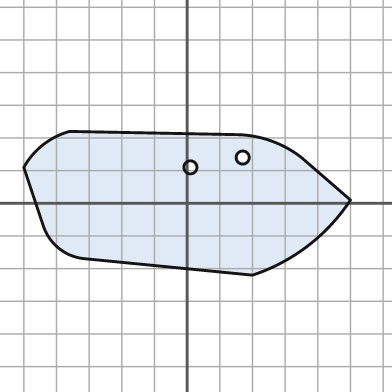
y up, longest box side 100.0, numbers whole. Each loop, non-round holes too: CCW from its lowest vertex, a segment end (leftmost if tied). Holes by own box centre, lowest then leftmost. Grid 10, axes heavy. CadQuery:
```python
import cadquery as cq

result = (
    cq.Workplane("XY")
    .moveTo(20.0, -22.0)
    .threePointArc((37.0, -13.0), (50.0, 1.0))
    .lineTo(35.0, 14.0)
    .threePointArc((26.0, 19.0), (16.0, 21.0))
    .lineTo(-36.0, 22.0)
    .threePointArc((-44.0, 18.0), (-50.0, 11.0))
    .lineTo(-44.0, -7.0)
    .threePointArc((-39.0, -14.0), (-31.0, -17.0))
    .close()
    .moveTo(1.0, 11.0)
    .circle(2.0)
    .moveTo(17.0, 14.0)
    .circle(2.0)
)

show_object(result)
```